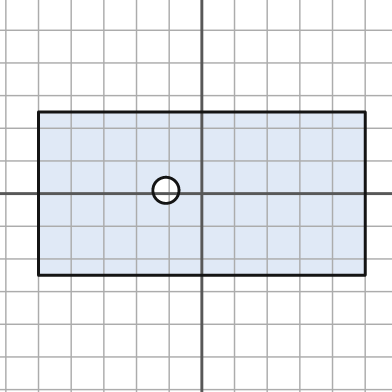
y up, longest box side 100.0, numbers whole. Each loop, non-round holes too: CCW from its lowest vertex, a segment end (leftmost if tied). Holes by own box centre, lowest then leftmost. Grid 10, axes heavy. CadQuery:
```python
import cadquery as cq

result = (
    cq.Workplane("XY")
    .moveTo(-50.0, -25.0)
    .lineTo(50.0, -25.0)
    .lineTo(50.0, 25.0)
    .lineTo(-50.0, 25.0)
    .close()
    .moveTo(-11.0, 1.0)
    .circle(4.0)
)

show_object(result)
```